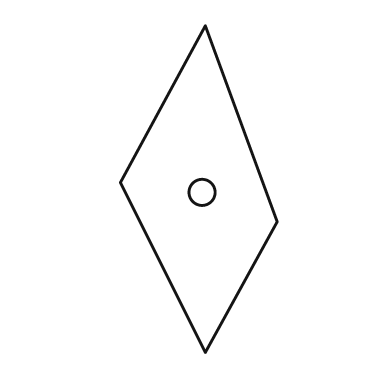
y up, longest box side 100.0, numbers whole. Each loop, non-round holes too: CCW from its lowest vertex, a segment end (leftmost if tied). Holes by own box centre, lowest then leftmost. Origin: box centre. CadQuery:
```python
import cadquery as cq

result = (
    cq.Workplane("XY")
    .moveTo(2.0, -50.0)
    .lineTo(24.0, -10.0)
    .lineTo(2.0, 50.0)
    .lineTo(-24.0, 2.0)
    .close()
    .moveTo(1.0, -1.0)
    .circle(4.0)
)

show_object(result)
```